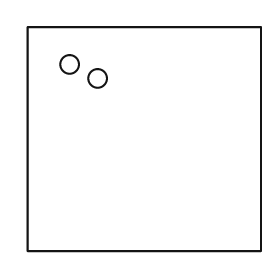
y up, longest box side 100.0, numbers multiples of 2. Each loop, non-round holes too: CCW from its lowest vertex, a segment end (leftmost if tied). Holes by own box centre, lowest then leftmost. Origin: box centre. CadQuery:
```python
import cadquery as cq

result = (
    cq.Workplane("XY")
    .moveTo(-50.0, -48.0)
    .lineTo(50.0, -48.0)
    .lineTo(50.0, 48.0)
    .lineTo(-50.0, 48.0)
    .close()
    .moveTo(-20.0, 26.0)
    .circle(4.0)
    .moveTo(-32.0, 32.0)
    .circle(4.0)
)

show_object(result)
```